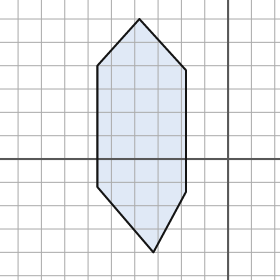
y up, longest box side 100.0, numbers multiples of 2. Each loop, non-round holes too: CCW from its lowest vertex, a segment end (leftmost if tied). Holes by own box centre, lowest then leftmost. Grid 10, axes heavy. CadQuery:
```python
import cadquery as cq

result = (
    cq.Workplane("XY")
    .moveTo(-32.0, -40.0)
    .lineTo(-18.0, -14.0)
    .lineTo(-18.0, 38.0)
    .lineTo(-38.0, 60.0)
    .lineTo(-56.0, 40.0)
    .lineTo(-56.0, -12.0)
    .close()
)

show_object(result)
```